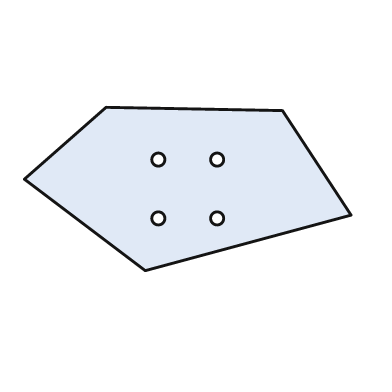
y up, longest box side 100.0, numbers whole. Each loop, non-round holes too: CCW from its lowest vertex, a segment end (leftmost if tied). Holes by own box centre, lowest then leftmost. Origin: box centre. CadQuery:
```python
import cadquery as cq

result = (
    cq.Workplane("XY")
    .moveTo(-13.0, -25.0)
    .lineTo(50.0, -8.0)
    .lineTo(29.0, 24.0)
    .lineTo(-25.0, 25.0)
    .lineTo(-50.0, 3.0)
    .close()
    .moveTo(-9.0, -9.0)
    .circle(2.0)
    .moveTo(9.0, -9.0)
    .circle(2.0)
    .moveTo(-9.0, 9.0)
    .circle(2.0)
    .moveTo(9.0, 9.0)
    .circle(2.0)
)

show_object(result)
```